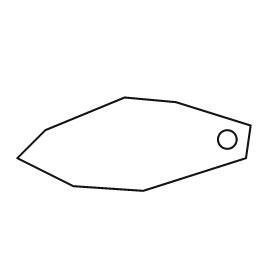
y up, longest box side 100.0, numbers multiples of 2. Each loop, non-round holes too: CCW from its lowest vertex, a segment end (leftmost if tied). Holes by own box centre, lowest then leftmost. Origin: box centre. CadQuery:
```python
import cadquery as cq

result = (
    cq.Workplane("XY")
    .moveTo(4.0, -20.0)
    .lineTo(48.0, -6.0)
    .lineTo(50.0, 8.0)
    .lineTo(18.0, 18.0)
    .lineTo(-4.0, 20.0)
    .lineTo(-38.0, 6.0)
    .lineTo(-50.0, -6.0)
    .lineTo(-26.0, -18.0)
    .close()
    .moveTo(40.0, 2.0)
    .circle(4.0)
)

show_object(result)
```